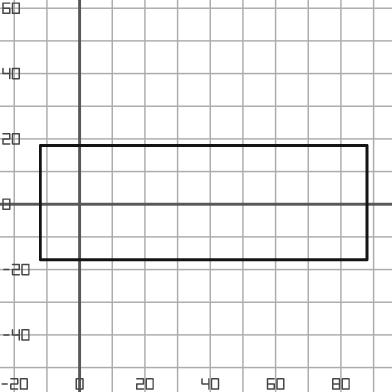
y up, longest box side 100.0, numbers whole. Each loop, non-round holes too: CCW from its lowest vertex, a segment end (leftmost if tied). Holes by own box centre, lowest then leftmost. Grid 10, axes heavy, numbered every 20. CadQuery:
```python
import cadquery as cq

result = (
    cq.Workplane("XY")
    .moveTo(-12.0, -17.0)
    .lineTo(88.0, -17.0)
    .lineTo(88.0, 18.0)
    .lineTo(-12.0, 18.0)
    .close()
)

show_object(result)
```